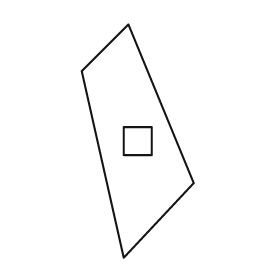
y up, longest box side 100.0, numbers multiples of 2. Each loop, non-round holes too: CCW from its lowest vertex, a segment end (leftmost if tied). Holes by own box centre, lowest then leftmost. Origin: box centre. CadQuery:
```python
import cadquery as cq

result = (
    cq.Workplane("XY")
    .moveTo(-6.0, -50.0)
    .lineTo(24.0, -18.0)
    .lineTo(-4.0, 50.0)
    .lineTo(-24.0, 30.0)
    .close()
    .moveTo(-6.0, -6.0)
    .lineTo(6.0, -6.0)
    .lineTo(6.0, 6.0)
    .lineTo(-6.0, 6.0)
    .close()
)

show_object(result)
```